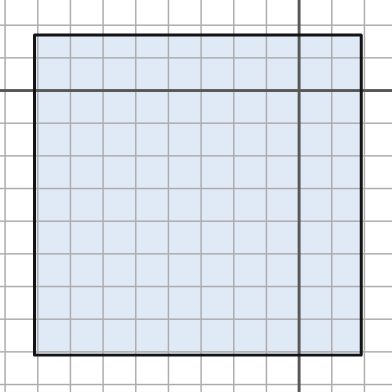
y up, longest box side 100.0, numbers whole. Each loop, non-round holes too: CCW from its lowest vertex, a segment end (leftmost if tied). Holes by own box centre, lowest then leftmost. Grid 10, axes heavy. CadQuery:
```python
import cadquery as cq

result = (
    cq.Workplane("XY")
    .moveTo(-81.0, -81.0)
    .lineTo(19.0, -81.0)
    .lineTo(19.0, 17.0)
    .lineTo(-81.0, 17.0)
    .close()
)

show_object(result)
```